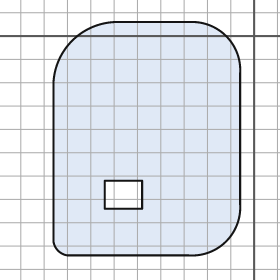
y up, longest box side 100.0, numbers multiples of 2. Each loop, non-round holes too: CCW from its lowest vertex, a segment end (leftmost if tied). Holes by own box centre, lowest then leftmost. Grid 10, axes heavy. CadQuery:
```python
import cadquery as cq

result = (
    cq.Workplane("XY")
    .moveTo(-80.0, -94.0)
    .lineTo(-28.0, -94.0)
    .threePointArc((-12.0, -88.0), (-6.0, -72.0))
    .lineTo(-6.0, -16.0)
    .threePointArc((-12.0, 0.0), (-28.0, 6.0))
    .lineTo(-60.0, 6.0)
    .threePointArc((-78.0, -2.0), (-86.0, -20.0))
    .lineTo(-86.0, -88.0)
    .threePointArc((-84.0, -92.0), (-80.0, -94.0))
    .close()
    .moveTo(-64.0, -74.0)
    .lineTo(-48.0, -74.0)
    .lineTo(-48.0, -62.0)
    .lineTo(-64.0, -62.0)
    .close()
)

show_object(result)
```